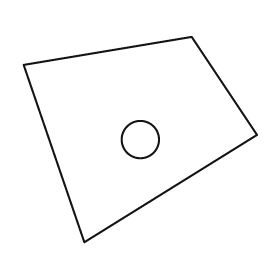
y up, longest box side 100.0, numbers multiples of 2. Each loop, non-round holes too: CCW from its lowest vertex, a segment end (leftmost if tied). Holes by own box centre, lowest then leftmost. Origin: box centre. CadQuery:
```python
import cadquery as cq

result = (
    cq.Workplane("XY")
    .moveTo(-24.0, -44.0)
    .lineTo(50.0, 2.0)
    .lineTo(22.0, 44.0)
    .lineTo(-50.0, 32.0)
    .close()
    .moveTo(0.0, 0.0)
    .circle(8.0)
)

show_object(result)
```